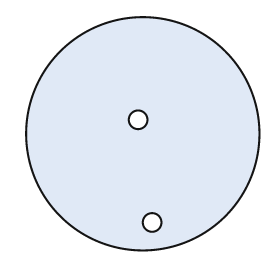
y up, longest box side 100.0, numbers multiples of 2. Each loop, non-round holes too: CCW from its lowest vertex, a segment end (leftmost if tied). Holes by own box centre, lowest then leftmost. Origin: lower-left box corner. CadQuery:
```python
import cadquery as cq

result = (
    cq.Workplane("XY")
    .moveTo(50.0, 50.0)
    .circle(50.0)
    .moveTo(54.0, 12.0)
    .circle(4.0)
    .moveTo(48.0, 56.0)
    .circle(4.0)
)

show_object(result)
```